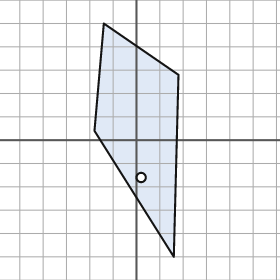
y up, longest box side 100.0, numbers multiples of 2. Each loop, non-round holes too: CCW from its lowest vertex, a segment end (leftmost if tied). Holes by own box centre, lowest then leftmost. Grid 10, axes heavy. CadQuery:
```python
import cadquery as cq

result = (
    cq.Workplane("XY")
    .moveTo(16.0, -50.0)
    .lineTo(18.0, 28.0)
    .lineTo(-14.0, 50.0)
    .lineTo(-18.0, 4.0)
    .close()
    .moveTo(2.0, -16.0)
    .circle(2.0)
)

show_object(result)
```